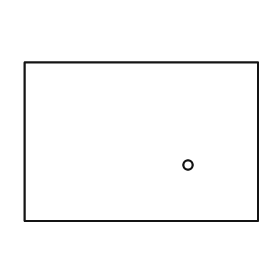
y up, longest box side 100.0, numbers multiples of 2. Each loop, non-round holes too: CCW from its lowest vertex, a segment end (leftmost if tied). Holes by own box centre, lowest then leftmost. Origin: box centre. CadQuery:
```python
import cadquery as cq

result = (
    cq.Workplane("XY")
    .moveTo(-50.0, -34.0)
    .lineTo(50.0, -34.0)
    .lineTo(50.0, 34.0)
    .lineTo(-50.0, 34.0)
    .close()
    .moveTo(20.0, -10.0)
    .circle(2.0)
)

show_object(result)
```